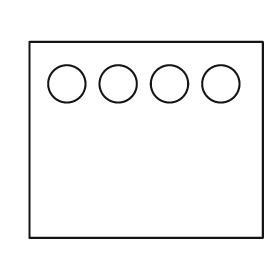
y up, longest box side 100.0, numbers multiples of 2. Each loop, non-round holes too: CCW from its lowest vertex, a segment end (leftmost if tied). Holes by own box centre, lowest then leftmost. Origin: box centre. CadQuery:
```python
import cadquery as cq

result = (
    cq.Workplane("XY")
    .moveTo(-50.0, -42.0)
    .lineTo(50.0, -42.0)
    .lineTo(50.0, 42.0)
    .lineTo(-50.0, 42.0)
    .close()
    .moveTo(-34.0, 24.0)
    .circle(8.0)
    .moveTo(-12.0, 24.0)
    .circle(8.0)
    .moveTo(10.0, 24.0)
    .circle(8.0)
    .moveTo(32.0, 24.0)
    .circle(8.0)
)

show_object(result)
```